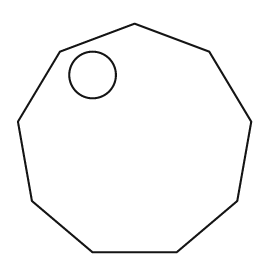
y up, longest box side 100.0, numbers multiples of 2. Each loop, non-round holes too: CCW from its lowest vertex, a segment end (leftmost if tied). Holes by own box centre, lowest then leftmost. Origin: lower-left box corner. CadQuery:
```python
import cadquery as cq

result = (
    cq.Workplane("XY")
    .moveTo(32.0, 0.0)
    .lineTo(68.0, 0.0)
    .lineTo(94.0, 22.0)
    .lineTo(100.0, 56.0)
    .lineTo(82.0, 86.0)
    .lineTo(50.0, 98.0)
    .lineTo(18.0, 86.0)
    .lineTo(0.0, 56.0)
    .lineTo(6.0, 22.0)
    .close()
    .moveTo(32.0, 76.0)
    .circle(10.0)
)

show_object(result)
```